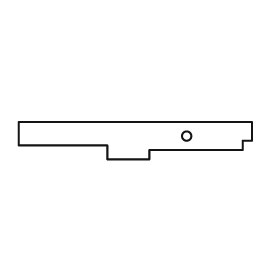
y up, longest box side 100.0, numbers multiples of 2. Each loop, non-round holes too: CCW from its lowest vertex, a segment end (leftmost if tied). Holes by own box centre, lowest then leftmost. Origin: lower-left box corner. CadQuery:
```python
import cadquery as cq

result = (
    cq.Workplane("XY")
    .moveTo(38.0, 0.0)
    .lineTo(56.0, 0.0)
    .lineTo(56.0, 4.0)
    .lineTo(96.0, 4.0)
    .lineTo(96.0, 8.0)
    .lineTo(100.0, 8.0)
    .lineTo(100.0, 16.0)
    .lineTo(0.0, 16.0)
    .lineTo(0.0, 6.0)
    .lineTo(38.0, 6.0)
    .close()
    .moveTo(72.0, 10.0)
    .circle(2.0)
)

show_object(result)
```